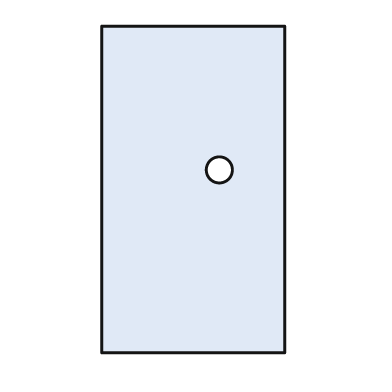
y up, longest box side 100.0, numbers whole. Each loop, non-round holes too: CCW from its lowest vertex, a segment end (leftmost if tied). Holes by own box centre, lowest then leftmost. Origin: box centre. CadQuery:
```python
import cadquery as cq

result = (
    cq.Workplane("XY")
    .moveTo(-28.0, -50.0)
    .lineTo(28.0, -50.0)
    .lineTo(28.0, 50.0)
    .lineTo(-28.0, 50.0)
    .close()
    .moveTo(8.0, 6.0)
    .circle(4.0)
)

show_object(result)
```